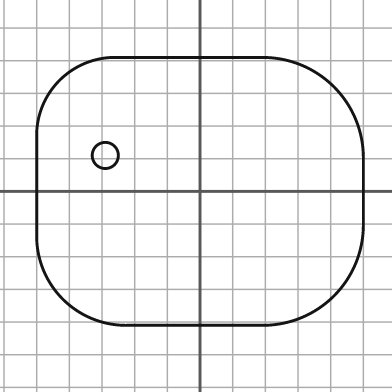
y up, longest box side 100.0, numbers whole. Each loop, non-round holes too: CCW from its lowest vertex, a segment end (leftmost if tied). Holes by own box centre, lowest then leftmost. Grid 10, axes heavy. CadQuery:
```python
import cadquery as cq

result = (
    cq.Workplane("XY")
    .moveTo(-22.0, -41.0)
    .lineTo(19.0, -41.0)
    .threePointArc((41.0, -32.0), (50.0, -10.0))
    .lineTo(50.0, 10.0)
    .threePointArc((41.0, 32.0), (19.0, 41.0))
    .lineTo(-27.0, 41.0)
    .threePointArc((-43.0, 34.0), (-50.0, 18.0))
    .lineTo(-50.0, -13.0)
    .threePointArc((-42.0, -33.0), (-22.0, -41.0))
    .close()
    .moveTo(-29.0, 11.0)
    .circle(4.0)
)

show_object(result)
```